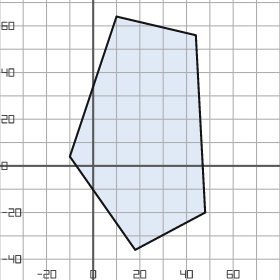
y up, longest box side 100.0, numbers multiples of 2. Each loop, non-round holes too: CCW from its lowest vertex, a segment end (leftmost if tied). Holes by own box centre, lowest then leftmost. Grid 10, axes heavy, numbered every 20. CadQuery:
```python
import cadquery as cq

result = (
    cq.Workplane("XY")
    .moveTo(18.0, -36.0)
    .lineTo(48.0, -20.0)
    .lineTo(44.0, 56.0)
    .lineTo(10.0, 64.0)
    .lineTo(-10.0, 4.0)
    .close()
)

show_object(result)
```